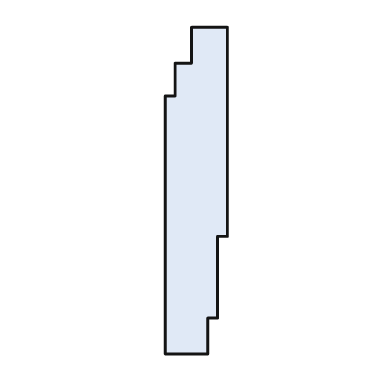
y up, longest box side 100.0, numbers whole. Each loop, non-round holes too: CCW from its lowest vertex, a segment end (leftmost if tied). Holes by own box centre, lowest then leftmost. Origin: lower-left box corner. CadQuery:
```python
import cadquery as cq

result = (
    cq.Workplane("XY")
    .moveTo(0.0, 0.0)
    .lineTo(13.0, 0.0)
    .lineTo(13.0, 11.0)
    .lineTo(16.0, 11.0)
    .lineTo(16.0, 36.0)
    .lineTo(19.0, 36.0)
    .lineTo(19.0, 100.0)
    .lineTo(8.0, 100.0)
    .lineTo(8.0, 89.0)
    .lineTo(3.0, 89.0)
    .lineTo(3.0, 79.0)
    .lineTo(0.0, 79.0)
    .close()
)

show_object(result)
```